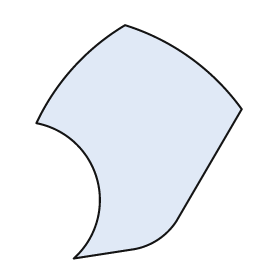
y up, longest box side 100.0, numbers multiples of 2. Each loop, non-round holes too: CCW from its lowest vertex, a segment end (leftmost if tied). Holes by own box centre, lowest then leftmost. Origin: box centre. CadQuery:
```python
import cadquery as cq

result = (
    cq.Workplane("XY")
    .moveTo(-28.0, -50.0)
    .lineTo(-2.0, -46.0)
    .threePointArc((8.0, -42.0), (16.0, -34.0))
    .lineTo(44.0, 14.0)
    .threePointArc((22.0, 36.0), (-6.0, 50.0))
    .threePointArc((-28.0, 32.0), (-44.0, 8.0))
    .threePointArc((-18.0, -16.0), (-28.0, -50.0))
    .close()
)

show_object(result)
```